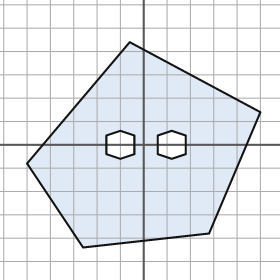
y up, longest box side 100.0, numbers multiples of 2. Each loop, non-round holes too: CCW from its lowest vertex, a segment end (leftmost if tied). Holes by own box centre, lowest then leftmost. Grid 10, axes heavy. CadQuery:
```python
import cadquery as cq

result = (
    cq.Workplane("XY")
    .moveTo(-26.0, -44.0)
    .lineTo(28.0, -38.0)
    .lineTo(50.0, 14.0)
    .lineTo(-6.0, 44.0)
    .lineTo(-50.0, -8.0)
    .close()
    .moveTo(-10.0, -6.0)
    .lineTo(-4.0, -4.0)
    .lineTo(-4.0, 4.0)
    .lineTo(-10.0, 6.0)
    .lineTo(-16.0, 4.0)
    .lineTo(-16.0, -4.0)
    .close()
    .moveTo(12.0, -6.0)
    .lineTo(18.0, -4.0)
    .lineTo(18.0, 4.0)
    .lineTo(12.0, 6.0)
    .lineTo(6.0, 4.0)
    .lineTo(6.0, -4.0)
    .close()
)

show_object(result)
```